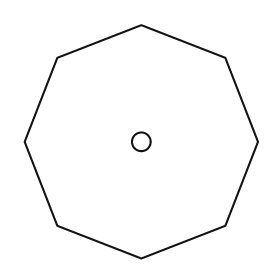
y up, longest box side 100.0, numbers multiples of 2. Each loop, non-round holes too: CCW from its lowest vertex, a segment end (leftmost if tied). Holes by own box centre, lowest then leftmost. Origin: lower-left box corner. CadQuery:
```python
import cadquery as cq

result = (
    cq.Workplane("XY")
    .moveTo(50.0, 0.0)
    .lineTo(86.0, 14.0)
    .lineTo(100.0, 50.0)
    .lineTo(86.0, 86.0)
    .lineTo(50.0, 100.0)
    .lineTo(14.0, 86.0)
    .lineTo(0.0, 50.0)
    .lineTo(14.0, 14.0)
    .close()
    .moveTo(50.0, 50.0)
    .circle(4.0)
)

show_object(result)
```